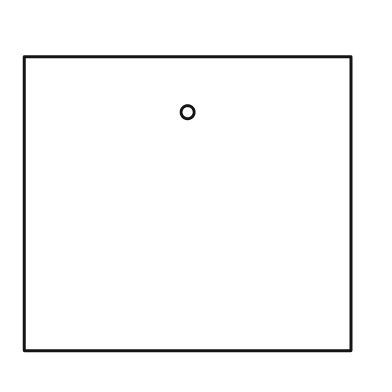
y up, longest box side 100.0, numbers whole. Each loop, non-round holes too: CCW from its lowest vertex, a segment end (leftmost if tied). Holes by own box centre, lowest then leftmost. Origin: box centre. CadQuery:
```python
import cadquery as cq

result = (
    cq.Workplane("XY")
    .moveTo(-50.0, -45.0)
    .lineTo(50.0, -45.0)
    .lineTo(50.0, 45.0)
    .lineTo(-50.0, 45.0)
    .close()
    .moveTo(0.0, 28.0)
    .circle(2.0)
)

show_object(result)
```